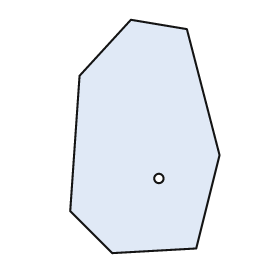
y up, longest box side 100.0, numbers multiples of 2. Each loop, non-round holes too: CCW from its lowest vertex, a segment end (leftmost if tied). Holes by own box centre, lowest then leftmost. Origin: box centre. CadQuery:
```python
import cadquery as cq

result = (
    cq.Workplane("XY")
    .moveTo(-14.0, -50.0)
    .lineTo(22.0, -48.0)
    .lineTo(32.0, -8.0)
    .lineTo(18.0, 46.0)
    .lineTo(-6.0, 50.0)
    .lineTo(-28.0, 26.0)
    .lineTo(-32.0, -32.0)
    .close()
    .moveTo(6.0, -18.0)
    .circle(2.0)
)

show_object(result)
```